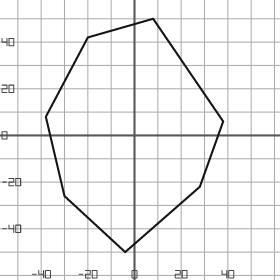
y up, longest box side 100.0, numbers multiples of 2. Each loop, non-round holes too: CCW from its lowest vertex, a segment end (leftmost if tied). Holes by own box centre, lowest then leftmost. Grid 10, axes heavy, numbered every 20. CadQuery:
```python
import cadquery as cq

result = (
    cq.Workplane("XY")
    .moveTo(-4.0, -50.0)
    .lineTo(28.0, -22.0)
    .lineTo(38.0, 6.0)
    .lineTo(8.0, 50.0)
    .lineTo(-20.0, 42.0)
    .lineTo(-38.0, 8.0)
    .lineTo(-30.0, -26.0)
    .close()
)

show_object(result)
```